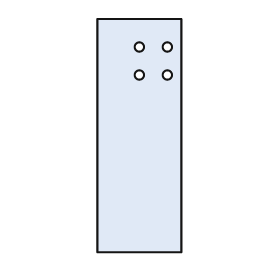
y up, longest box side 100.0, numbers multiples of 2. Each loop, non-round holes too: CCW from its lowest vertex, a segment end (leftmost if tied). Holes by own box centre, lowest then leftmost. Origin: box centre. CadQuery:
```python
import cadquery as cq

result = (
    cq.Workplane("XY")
    .moveTo(-18.0, -50.0)
    .lineTo(18.0, -50.0)
    .lineTo(18.0, 50.0)
    .lineTo(-18.0, 50.0)
    .close()
    .moveTo(0.0, 26.0)
    .circle(2.0)
    .moveTo(12.0, 26.0)
    .circle(2.0)
    .moveTo(0.0, 38.0)
    .circle(2.0)
    .moveTo(12.0, 38.0)
    .circle(2.0)
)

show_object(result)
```